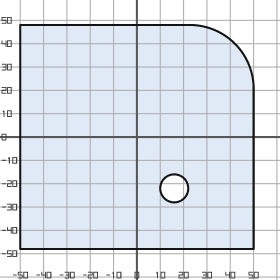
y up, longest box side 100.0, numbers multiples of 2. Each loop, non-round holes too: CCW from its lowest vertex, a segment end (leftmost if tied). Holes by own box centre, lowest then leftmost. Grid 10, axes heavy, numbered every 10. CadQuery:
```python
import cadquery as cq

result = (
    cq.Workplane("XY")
    .moveTo(-50.0, -48.0)
    .lineTo(50.0, -48.0)
    .lineTo(50.0, 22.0)
    .threePointArc((42.0, 40.0), (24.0, 48.0))
    .lineTo(-50.0, 48.0)
    .close()
    .moveTo(16.0, -22.0)
    .circle(6.0)
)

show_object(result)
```